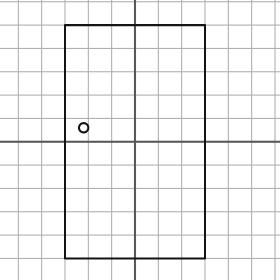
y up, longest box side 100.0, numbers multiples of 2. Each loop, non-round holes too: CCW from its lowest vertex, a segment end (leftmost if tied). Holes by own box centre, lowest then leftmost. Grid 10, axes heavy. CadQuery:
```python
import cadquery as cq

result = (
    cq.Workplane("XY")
    .moveTo(-30.0, -50.0)
    .lineTo(30.0, -50.0)
    .lineTo(30.0, 50.0)
    .lineTo(-30.0, 50.0)
    .close()
    .moveTo(-22.0, 6.0)
    .circle(2.0)
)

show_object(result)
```